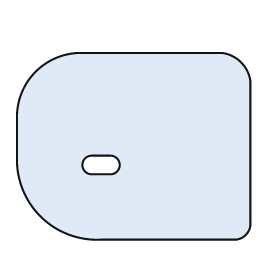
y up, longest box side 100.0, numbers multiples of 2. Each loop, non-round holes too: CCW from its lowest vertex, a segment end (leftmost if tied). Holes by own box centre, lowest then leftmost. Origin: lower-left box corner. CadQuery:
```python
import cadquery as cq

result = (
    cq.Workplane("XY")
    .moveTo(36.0, 0.0)
    .lineTo(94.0, 0.0)
    .threePointArc((98.0, 2.0), (100.0, 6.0))
    .lineTo(100.0, 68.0)
    .threePointArc((96.0, 76.0), (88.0, 80.0))
    .lineTo(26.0, 80.0)
    .threePointArc((8.0, 72.0), (0.0, 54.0))
    .lineTo(0.0, 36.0)
    .threePointArc((10.0, 10.0), (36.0, 0.0))
    .close()
    .moveTo(32.0, 28.0)
    .lineTo(40.0, 28.0)
    .threePointArc((44.0, 32.0), (40.0, 36.0))
    .lineTo(32.0, 36.0)
    .threePointArc((28.0, 32.0), (32.0, 28.0))
    .close()
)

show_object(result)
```